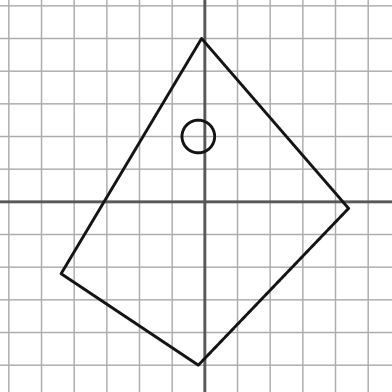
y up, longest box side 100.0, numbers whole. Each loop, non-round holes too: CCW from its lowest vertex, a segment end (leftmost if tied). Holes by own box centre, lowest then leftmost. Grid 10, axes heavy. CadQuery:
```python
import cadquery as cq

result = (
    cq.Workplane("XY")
    .moveTo(-2.0, -50.0)
    .lineTo(44.0, -2.0)
    .lineTo(-1.0, 50.0)
    .lineTo(-44.0, -22.0)
    .close()
    .moveTo(-2.0, 20.0)
    .circle(5.0)
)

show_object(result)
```